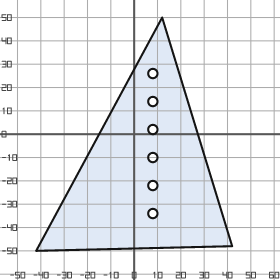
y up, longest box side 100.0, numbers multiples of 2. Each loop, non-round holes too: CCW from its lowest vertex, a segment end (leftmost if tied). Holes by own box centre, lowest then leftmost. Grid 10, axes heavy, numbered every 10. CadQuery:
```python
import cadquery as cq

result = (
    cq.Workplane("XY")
    .moveTo(-42.0, -50.0)
    .lineTo(42.0, -48.0)
    .lineTo(12.0, 50.0)
    .close()
    .moveTo(8.0, -34.0)
    .circle(2.0)
    .moveTo(8.0, -22.0)
    .circle(2.0)
    .moveTo(8.0, -10.0)
    .circle(2.0)
    .moveTo(8.0, 2.0)
    .circle(2.0)
    .moveTo(8.0, 14.0)
    .circle(2.0)
    .moveTo(8.0, 26.0)
    .circle(2.0)
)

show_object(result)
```